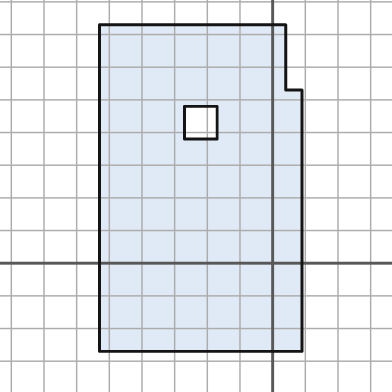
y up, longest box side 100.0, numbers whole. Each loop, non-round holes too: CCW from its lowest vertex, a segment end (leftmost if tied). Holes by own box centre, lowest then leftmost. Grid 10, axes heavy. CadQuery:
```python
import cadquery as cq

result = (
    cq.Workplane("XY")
    .moveTo(-53.0, -27.0)
    .lineTo(9.0, -27.0)
    .lineTo(9.0, 53.0)
    .lineTo(4.0, 53.0)
    .lineTo(4.0, 73.0)
    .lineTo(-53.0, 73.0)
    .close()
    .moveTo(-27.0, 38.0)
    .lineTo(-17.0, 38.0)
    .lineTo(-17.0, 48.0)
    .lineTo(-27.0, 48.0)
    .close()
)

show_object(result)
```